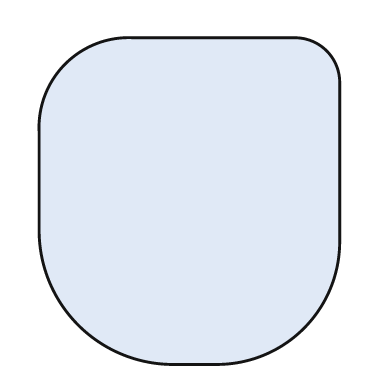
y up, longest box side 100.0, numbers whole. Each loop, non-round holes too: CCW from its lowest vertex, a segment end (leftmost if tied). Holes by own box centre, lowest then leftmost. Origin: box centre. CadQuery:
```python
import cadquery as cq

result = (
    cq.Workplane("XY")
    .moveTo(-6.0, -50.0)
    .lineTo(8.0, -50.0)
    .threePointArc((35.0, -39.0), (46.0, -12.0))
    .lineTo(46.0, 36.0)
    .threePointArc((42.0, 46.0), (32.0, 50.0))
    .lineTo(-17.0, 50.0)
    .threePointArc((-38.0, 42.0), (-46.0, 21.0))
    .lineTo(-46.0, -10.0)
    .threePointArc((-34.0, -38.0), (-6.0, -50.0))
    .close()
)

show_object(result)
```